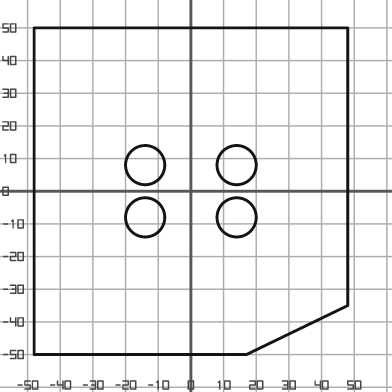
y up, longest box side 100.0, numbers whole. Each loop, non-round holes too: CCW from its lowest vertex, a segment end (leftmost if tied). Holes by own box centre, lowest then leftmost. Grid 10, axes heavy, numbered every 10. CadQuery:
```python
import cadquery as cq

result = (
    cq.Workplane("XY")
    .moveTo(-48.0, -50.0)
    .lineTo(17.0, -50.0)
    .lineTo(48.0, -35.0)
    .lineTo(48.0, 50.0)
    .lineTo(-48.0, 50.0)
    .close()
    .moveTo(-14.0, -8.0)
    .circle(6.0)
    .moveTo(14.0, -8.0)
    .circle(6.0)
    .moveTo(-14.0, 8.0)
    .circle(6.0)
    .moveTo(14.0, 8.0)
    .circle(6.0)
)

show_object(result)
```